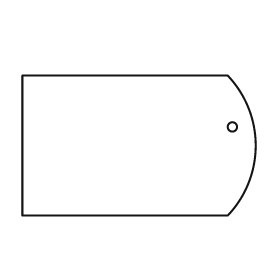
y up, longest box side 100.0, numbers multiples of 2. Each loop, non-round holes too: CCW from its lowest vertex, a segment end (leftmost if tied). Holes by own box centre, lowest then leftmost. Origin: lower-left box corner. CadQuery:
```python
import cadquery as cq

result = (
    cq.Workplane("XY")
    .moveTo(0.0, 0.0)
    .lineTo(88.0, 0.0)
    .threePointArc((100.0, 30.0), (88.0, 60.0))
    .lineTo(0.0, 60.0)
    .close()
    .moveTo(90.0, 38.0)
    .circle(2.0)
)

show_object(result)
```